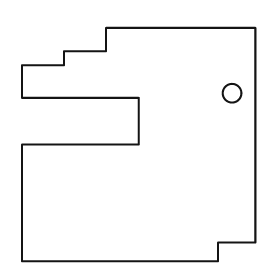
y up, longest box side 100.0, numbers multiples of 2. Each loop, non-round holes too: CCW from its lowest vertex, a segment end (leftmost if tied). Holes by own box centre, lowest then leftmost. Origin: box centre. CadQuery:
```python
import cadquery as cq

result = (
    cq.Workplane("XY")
    .moveTo(-50.0, -50.0)
    .lineTo(34.0, -50.0)
    .lineTo(34.0, -42.0)
    .lineTo(50.0, -42.0)
    .lineTo(50.0, 50.0)
    .lineTo(-14.0, 50.0)
    .lineTo(-14.0, 40.0)
    .lineTo(-32.0, 40.0)
    .lineTo(-32.0, 34.0)
    .lineTo(-50.0, 34.0)
    .lineTo(-50.0, 20.0)
    .lineTo(0.0, 20.0)
    .lineTo(0.0, 0.0)
    .lineTo(-50.0, 0.0)
    .close()
    .moveTo(40.0, 22.0)
    .circle(4.0)
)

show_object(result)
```